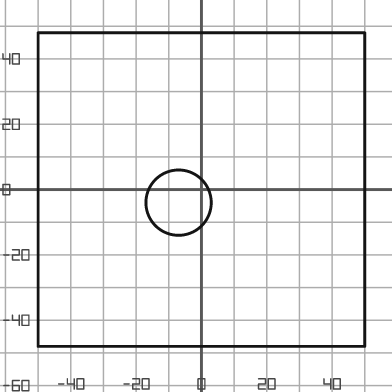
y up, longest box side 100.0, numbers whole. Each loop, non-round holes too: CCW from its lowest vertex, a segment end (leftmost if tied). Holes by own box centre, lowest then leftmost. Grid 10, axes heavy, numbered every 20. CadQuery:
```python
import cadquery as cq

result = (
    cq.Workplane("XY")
    .moveTo(-50.0, -48.0)
    .lineTo(50.0, -48.0)
    .lineTo(50.0, 48.0)
    .lineTo(-50.0, 48.0)
    .close()
    .moveTo(-7.0, -4.0)
    .circle(10.0)
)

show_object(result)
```